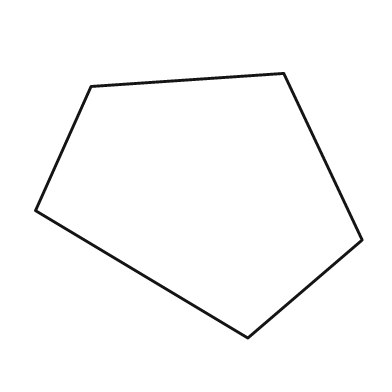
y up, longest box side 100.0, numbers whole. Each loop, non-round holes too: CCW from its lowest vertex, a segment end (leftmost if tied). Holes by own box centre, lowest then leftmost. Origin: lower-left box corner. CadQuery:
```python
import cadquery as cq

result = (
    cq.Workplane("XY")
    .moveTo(65.0, 0.0)
    .lineTo(100.0, 30.0)
    .lineTo(76.0, 81.0)
    .lineTo(17.0, 77.0)
    .lineTo(0.0, 39.0)
    .close()
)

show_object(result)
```